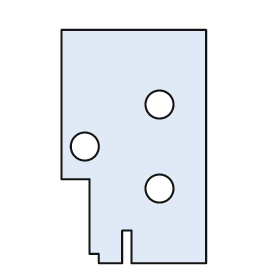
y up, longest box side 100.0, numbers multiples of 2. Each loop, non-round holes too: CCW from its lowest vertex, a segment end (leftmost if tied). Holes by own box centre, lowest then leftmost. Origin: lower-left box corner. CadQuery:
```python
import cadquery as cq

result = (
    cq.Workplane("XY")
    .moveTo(16.0, 0.0)
    .lineTo(26.0, 0.0)
    .lineTo(26.0, 14.0)
    .lineTo(30.0, 14.0)
    .lineTo(30.0, 0.0)
    .lineTo(62.0, 0.0)
    .lineTo(62.0, 100.0)
    .lineTo(0.0, 100.0)
    .lineTo(0.0, 36.0)
    .lineTo(12.0, 36.0)
    .lineTo(12.0, 4.0)
    .lineTo(16.0, 4.0)
    .close()
    .moveTo(42.0, 32.0)
    .circle(6.0)
    .moveTo(10.0, 50.0)
    .circle(6.0)
    .moveTo(42.0, 68.0)
    .circle(6.0)
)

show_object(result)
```